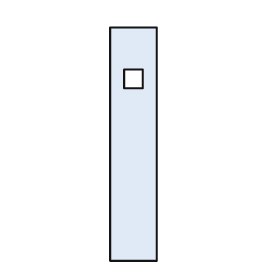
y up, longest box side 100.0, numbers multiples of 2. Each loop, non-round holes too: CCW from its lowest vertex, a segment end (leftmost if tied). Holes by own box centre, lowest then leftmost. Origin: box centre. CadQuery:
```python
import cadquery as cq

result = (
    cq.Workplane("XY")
    .moveTo(-10.0, -50.0)
    .lineTo(10.0, -50.0)
    .lineTo(10.0, 50.0)
    .lineTo(-10.0, 50.0)
    .close()
    .moveTo(-4.0, 24.0)
    .lineTo(4.0, 24.0)
    .lineTo(4.0, 32.0)
    .lineTo(-4.0, 32.0)
    .close()
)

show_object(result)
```